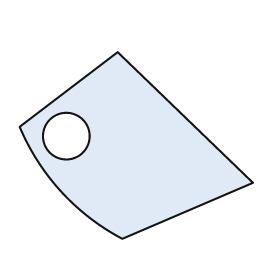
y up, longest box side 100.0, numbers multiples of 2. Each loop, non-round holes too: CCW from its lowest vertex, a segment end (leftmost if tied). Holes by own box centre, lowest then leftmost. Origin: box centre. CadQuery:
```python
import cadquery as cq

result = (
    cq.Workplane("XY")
    .moveTo(-6.0, -40.0)
    .lineTo(50.0, -16.0)
    .lineTo(-8.0, 40.0)
    .lineTo(-50.0, 8.0)
    .threePointArc((-32.0, -20.0), (-6.0, -40.0))
    .close()
    .moveTo(-30.0, 4.0)
    .circle(10.0)
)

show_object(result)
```